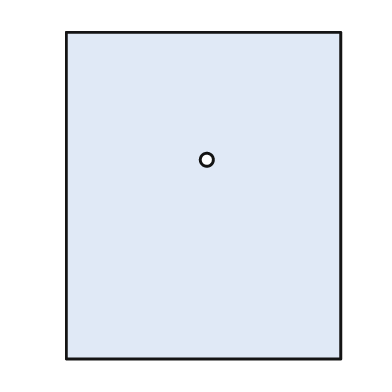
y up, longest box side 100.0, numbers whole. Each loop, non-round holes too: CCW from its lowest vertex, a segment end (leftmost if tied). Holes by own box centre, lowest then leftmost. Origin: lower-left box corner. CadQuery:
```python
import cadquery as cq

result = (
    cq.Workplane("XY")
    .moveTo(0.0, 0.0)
    .lineTo(84.0, 0.0)
    .lineTo(84.0, 100.0)
    .lineTo(0.0, 100.0)
    .close()
    .moveTo(43.0, 61.0)
    .circle(2.0)
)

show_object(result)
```